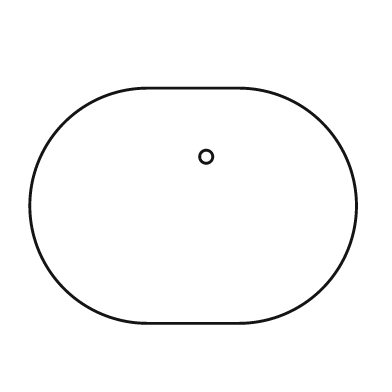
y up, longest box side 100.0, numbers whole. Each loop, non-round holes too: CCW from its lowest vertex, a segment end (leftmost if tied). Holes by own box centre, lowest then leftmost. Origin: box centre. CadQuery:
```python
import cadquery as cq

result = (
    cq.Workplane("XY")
    .moveTo(-14.0, -36.0)
    .lineTo(14.0, -36.0)
    .threePointArc((50.0, 0.0), (14.0, 36.0))
    .lineTo(-14.0, 36.0)
    .threePointArc((-50.0, 0.0), (-14.0, -36.0))
    .close()
    .moveTo(4.0, 15.0)
    .circle(2.0)
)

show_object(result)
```